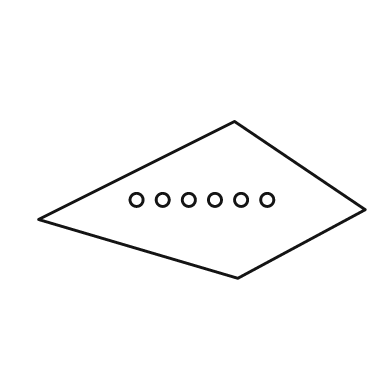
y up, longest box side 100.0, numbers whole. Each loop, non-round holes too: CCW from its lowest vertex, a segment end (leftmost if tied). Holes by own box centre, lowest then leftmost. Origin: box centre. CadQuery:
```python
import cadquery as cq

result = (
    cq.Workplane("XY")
    .moveTo(11.0, -24.0)
    .lineTo(50.0, -3.0)
    .lineTo(10.0, 24.0)
    .lineTo(-50.0, -6.0)
    .close()
    .moveTo(-20.0, 0.0)
    .circle(2.0)
    .moveTo(-12.0, 0.0)
    .circle(2.0)
    .moveTo(-4.0, 0.0)
    .circle(2.0)
    .moveTo(4.0, 0.0)
    .circle(2.0)
    .moveTo(12.0, 0.0)
    .circle(2.0)
    .moveTo(20.0, 0.0)
    .circle(2.0)
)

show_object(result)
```